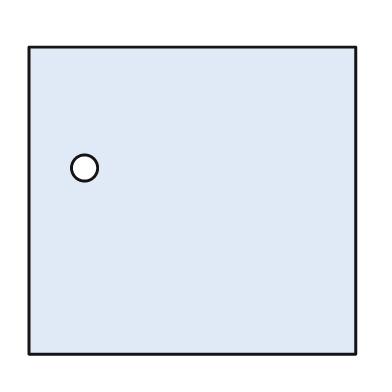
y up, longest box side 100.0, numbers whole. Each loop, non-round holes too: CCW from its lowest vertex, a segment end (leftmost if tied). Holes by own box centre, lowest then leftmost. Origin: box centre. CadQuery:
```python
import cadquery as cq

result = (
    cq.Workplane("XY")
    .moveTo(-50.0, -47.0)
    .lineTo(50.0, -47.0)
    .lineTo(50.0, 47.0)
    .lineTo(-50.0, 47.0)
    .close()
    .moveTo(-33.0, 10.0)
    .circle(4.0)
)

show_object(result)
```